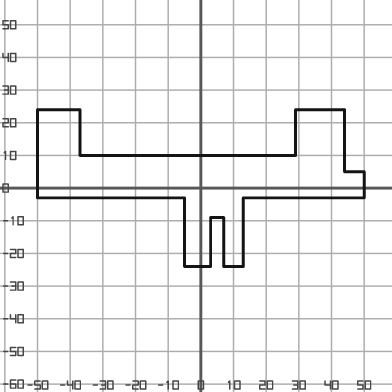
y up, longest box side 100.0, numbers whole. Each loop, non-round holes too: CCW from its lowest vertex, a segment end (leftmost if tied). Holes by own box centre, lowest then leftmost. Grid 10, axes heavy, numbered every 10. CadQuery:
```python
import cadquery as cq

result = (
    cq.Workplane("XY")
    .moveTo(-5.0, -24.0)
    .lineTo(3.0, -24.0)
    .lineTo(3.0, -9.0)
    .lineTo(7.0, -9.0)
    .lineTo(7.0, -24.0)
    .lineTo(13.0, -24.0)
    .lineTo(13.0, -3.0)
    .lineTo(50.0, -3.0)
    .lineTo(50.0, 5.0)
    .lineTo(44.0, 5.0)
    .lineTo(44.0, 24.0)
    .lineTo(29.0, 24.0)
    .lineTo(29.0, 10.0)
    .lineTo(-37.0, 10.0)
    .lineTo(-37.0, 24.0)
    .lineTo(-50.0, 24.0)
    .lineTo(-50.0, -3.0)
    .lineTo(-5.0, -3.0)
    .close()
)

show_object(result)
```